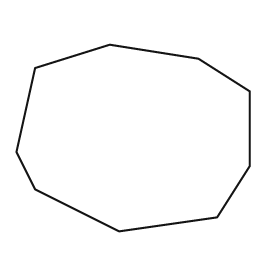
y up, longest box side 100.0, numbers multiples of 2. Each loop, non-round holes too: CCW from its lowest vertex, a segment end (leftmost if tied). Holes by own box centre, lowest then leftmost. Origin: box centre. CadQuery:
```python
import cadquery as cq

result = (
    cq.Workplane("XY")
    .moveTo(-6.0, -40.0)
    .lineTo(36.0, -34.0)
    .lineTo(50.0, -12.0)
    .lineTo(50.0, 20.0)
    .lineTo(28.0, 34.0)
    .lineTo(-10.0, 40.0)
    .lineTo(-42.0, 30.0)
    .lineTo(-50.0, -6.0)
    .lineTo(-42.0, -22.0)
    .close()
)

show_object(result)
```